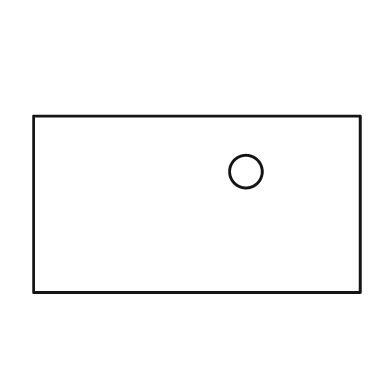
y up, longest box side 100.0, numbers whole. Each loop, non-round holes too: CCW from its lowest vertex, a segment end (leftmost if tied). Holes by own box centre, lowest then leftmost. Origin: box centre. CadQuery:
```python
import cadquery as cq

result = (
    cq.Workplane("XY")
    .moveTo(-50.0, -27.0)
    .lineTo(50.0, -27.0)
    .lineTo(50.0, 27.0)
    .lineTo(-50.0, 27.0)
    .close()
    .moveTo(15.0, 10.0)
    .circle(5.0)
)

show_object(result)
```